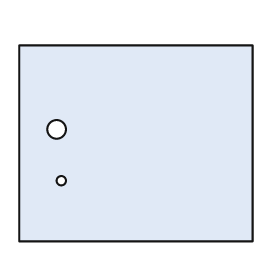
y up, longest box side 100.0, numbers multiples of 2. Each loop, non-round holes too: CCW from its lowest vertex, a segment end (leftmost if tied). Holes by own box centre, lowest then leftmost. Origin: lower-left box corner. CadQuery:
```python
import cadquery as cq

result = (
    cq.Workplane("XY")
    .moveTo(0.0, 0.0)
    .lineTo(100.0, 0.0)
    .lineTo(100.0, 84.0)
    .lineTo(0.0, 84.0)
    .close()
    .moveTo(18.0, 26.0)
    .circle(2.0)
    .moveTo(16.0, 48.0)
    .circle(4.0)
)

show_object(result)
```